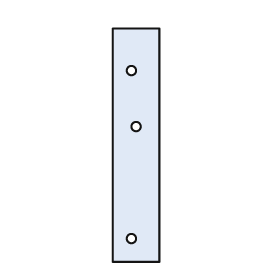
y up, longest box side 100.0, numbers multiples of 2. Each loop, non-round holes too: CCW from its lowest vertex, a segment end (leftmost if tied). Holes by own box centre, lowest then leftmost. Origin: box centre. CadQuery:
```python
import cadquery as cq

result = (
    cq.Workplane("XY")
    .moveTo(-10.0, -50.0)
    .lineTo(10.0, -50.0)
    .lineTo(10.0, 50.0)
    .lineTo(-10.0, 50.0)
    .close()
    .moveTo(-2.0, -40.0)
    .circle(2.0)
    .moveTo(0.0, 8.0)
    .circle(2.0)
    .moveTo(-2.0, 32.0)
    .circle(2.0)
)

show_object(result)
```